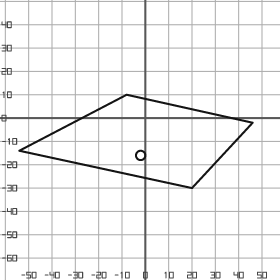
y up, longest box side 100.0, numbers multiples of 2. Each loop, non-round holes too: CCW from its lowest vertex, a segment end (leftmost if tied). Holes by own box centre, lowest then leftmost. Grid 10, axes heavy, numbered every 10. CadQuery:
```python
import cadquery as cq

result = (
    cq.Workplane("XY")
    .moveTo(20.0, -30.0)
    .lineTo(46.0, -2.0)
    .lineTo(-8.0, 10.0)
    .lineTo(-54.0, -14.0)
    .close()
    .moveTo(-2.0, -16.0)
    .circle(2.0)
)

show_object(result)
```